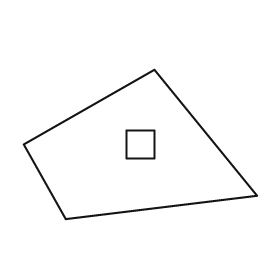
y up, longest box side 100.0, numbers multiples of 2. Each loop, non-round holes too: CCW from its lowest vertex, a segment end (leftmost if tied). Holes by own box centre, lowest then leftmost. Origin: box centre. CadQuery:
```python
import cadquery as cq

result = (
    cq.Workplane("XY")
    .moveTo(-32.0, -32.0)
    .lineTo(50.0, -22.0)
    .lineTo(6.0, 32.0)
    .lineTo(-50.0, 0.0)
    .close()
    .moveTo(-6.0, -6.0)
    .lineTo(6.0, -6.0)
    .lineTo(6.0, 6.0)
    .lineTo(-6.0, 6.0)
    .close()
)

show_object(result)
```